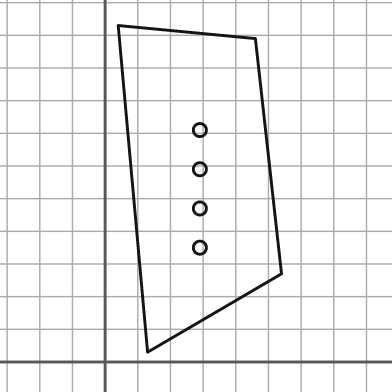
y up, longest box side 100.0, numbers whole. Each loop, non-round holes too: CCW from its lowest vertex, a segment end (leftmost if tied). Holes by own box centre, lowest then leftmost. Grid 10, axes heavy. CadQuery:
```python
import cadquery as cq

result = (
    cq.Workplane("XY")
    .moveTo(13.0, 3.0)
    .lineTo(54.0, 27.0)
    .lineTo(46.0, 99.0)
    .lineTo(4.0, 103.0)
    .close()
    .moveTo(29.0, 35.0)
    .circle(2.0)
    .moveTo(29.0, 47.0)
    .circle(2.0)
    .moveTo(29.0, 59.0)
    .circle(2.0)
    .moveTo(29.0, 71.0)
    .circle(2.0)
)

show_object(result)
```